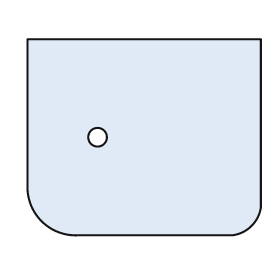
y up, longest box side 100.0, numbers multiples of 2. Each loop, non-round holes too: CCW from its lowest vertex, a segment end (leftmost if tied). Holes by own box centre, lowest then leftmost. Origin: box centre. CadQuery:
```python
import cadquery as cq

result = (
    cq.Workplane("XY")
    .moveTo(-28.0, -42.0)
    .lineTo(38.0, -42.0)
    .threePointArc((46.0, -38.0), (50.0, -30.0))
    .lineTo(50.0, 42.0)
    .lineTo(-50.0, 42.0)
    .lineTo(-50.0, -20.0)
    .threePointArc((-44.0, -36.0), (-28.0, -42.0))
    .close()
    .moveTo(-20.0, 0.0)
    .circle(4.0)
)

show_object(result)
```